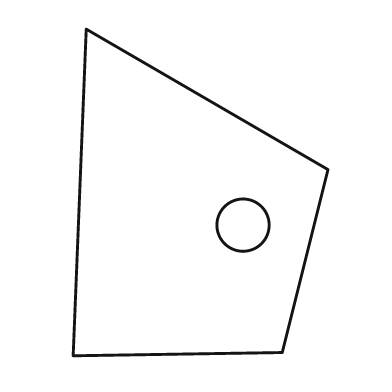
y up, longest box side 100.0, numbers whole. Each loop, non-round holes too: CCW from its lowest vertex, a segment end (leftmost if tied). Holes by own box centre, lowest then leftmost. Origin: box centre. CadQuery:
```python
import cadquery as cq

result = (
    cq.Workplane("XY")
    .moveTo(-39.0, -50.0)
    .lineTo(25.0, -49.0)
    .lineTo(39.0, 7.0)
    .lineTo(-35.0, 50.0)
    .close()
    .moveTo(13.0, -10.0)
    .circle(8.0)
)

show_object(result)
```